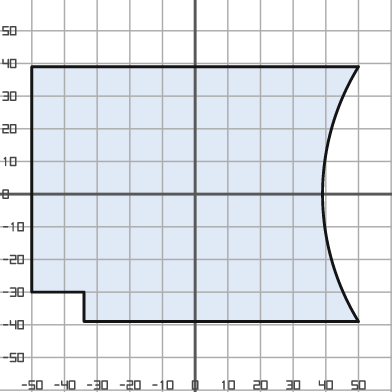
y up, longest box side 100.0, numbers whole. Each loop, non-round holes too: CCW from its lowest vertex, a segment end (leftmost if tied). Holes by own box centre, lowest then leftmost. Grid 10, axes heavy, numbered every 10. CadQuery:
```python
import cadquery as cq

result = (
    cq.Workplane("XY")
    .moveTo(-34.0, -39.0)
    .lineTo(50.0, -39.0)
    .threePointArc((39.0, 0.0), (50.0, 39.0))
    .lineTo(-50.0, 39.0)
    .lineTo(-50.0, -30.0)
    .lineTo(-34.0, -30.0)
    .close()
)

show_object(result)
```